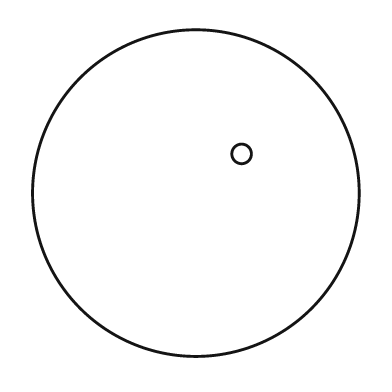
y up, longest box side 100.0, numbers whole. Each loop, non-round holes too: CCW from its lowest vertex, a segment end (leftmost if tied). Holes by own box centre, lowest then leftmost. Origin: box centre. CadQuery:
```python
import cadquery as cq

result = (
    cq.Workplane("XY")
    .moveTo(0.0, 0.0)
    .circle(50.0)
    .moveTo(14.0, 12.0)
    .circle(3.0)
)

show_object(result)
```